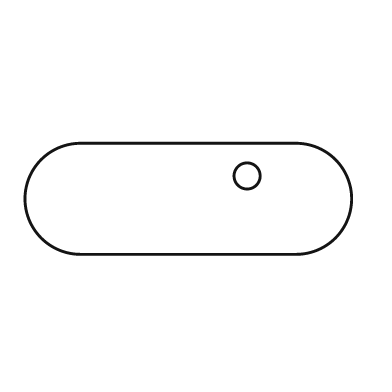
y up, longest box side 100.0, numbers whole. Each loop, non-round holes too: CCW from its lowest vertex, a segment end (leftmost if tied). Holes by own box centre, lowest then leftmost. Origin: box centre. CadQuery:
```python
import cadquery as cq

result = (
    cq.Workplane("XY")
    .moveTo(-33.0, -17.0)
    .lineTo(33.0, -17.0)
    .threePointArc((50.0, 0.0), (33.0, 17.0))
    .lineTo(-33.0, 17.0)
    .threePointArc((-50.0, 0.0), (-33.0, -17.0))
    .close()
    .moveTo(18.0, 7.0)
    .circle(4.0)
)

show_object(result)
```